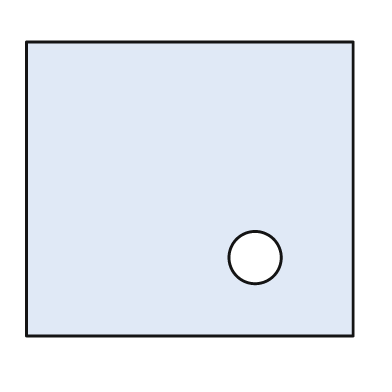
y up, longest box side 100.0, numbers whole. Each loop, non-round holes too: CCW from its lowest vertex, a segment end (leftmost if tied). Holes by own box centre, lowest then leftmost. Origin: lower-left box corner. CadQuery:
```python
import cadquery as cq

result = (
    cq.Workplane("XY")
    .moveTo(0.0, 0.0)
    .lineTo(100.0, 0.0)
    .lineTo(100.0, 90.0)
    .lineTo(0.0, 90.0)
    .close()
    .moveTo(70.0, 24.0)
    .circle(8.0)
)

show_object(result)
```